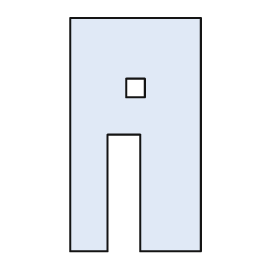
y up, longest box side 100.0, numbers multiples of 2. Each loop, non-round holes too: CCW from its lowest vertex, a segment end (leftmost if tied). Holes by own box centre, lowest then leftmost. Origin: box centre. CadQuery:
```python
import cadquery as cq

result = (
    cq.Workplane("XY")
    .moveTo(-28.0, -50.0)
    .lineTo(-12.0, -50.0)
    .lineTo(-12.0, 0.0)
    .lineTo(2.0, 0.0)
    .lineTo(2.0, -50.0)
    .lineTo(28.0, -50.0)
    .lineTo(28.0, 50.0)
    .lineTo(-28.0, 50.0)
    .close()
    .moveTo(-4.0, 16.0)
    .lineTo(4.0, 16.0)
    .lineTo(4.0, 24.0)
    .lineTo(-4.0, 24.0)
    .close()
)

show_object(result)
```